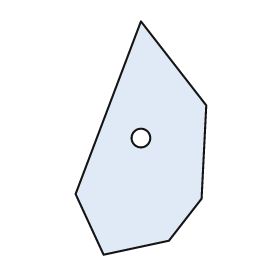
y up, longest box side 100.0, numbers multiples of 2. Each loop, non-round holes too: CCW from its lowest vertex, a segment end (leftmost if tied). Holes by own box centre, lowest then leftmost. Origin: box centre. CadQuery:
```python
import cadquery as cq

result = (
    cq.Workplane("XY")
    .moveTo(-16.0, -50.0)
    .lineTo(12.0, -44.0)
    .lineTo(26.0, -26.0)
    .lineTo(28.0, 14.0)
    .lineTo(0.0, 50.0)
    .lineTo(-28.0, -24.0)
    .close()
    .moveTo(0.0, 0.0)
    .circle(4.0)
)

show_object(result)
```